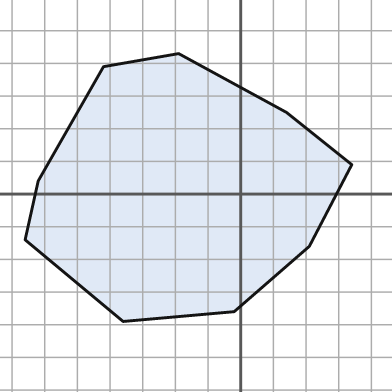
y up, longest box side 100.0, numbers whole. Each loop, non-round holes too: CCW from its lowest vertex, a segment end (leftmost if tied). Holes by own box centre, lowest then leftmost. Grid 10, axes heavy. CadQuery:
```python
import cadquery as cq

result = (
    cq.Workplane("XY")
    .moveTo(-36.0, -39.0)
    .lineTo(-2.0, -36.0)
    .lineTo(21.0, -16.0)
    .lineTo(34.0, 9.0)
    .lineTo(14.0, 25.0)
    .lineTo(-19.0, 43.0)
    .lineTo(-42.0, 39.0)
    .lineTo(-62.0, 4.0)
    .lineTo(-66.0, -14.0)
    .close()
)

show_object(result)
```